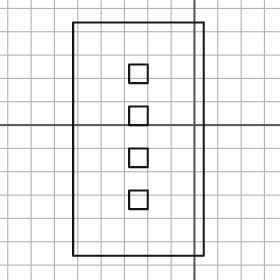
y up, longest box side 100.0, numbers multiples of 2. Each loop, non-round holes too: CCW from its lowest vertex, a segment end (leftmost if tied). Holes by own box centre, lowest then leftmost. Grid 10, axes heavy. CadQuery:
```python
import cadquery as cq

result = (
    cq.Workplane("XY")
    .moveTo(-52.0, -56.0)
    .lineTo(4.0, -56.0)
    .lineTo(4.0, 44.0)
    .lineTo(-52.0, 44.0)
    .close()
    .moveTo(-28.0, -36.0)
    .lineTo(-20.0, -36.0)
    .lineTo(-20.0, -28.0)
    .lineTo(-28.0, -28.0)
    .close()
    .moveTo(-28.0, -18.0)
    .lineTo(-20.0, -18.0)
    .lineTo(-20.0, -10.0)
    .lineTo(-28.0, -10.0)
    .close()
    .moveTo(-28.0, 0.0)
    .lineTo(-20.0, 0.0)
    .lineTo(-20.0, 8.0)
    .lineTo(-28.0, 8.0)
    .close()
    .moveTo(-28.0, 18.0)
    .lineTo(-20.0, 18.0)
    .lineTo(-20.0, 26.0)
    .lineTo(-28.0, 26.0)
    .close()
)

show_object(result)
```